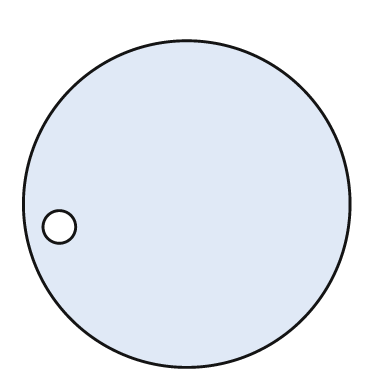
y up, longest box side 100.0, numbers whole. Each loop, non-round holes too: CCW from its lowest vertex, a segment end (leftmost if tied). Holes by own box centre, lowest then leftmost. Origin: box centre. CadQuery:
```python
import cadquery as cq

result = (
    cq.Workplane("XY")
    .moveTo(0.0, 0.0)
    .circle(50.0)
    .moveTo(-39.0, -7.0)
    .circle(5.0)
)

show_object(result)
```